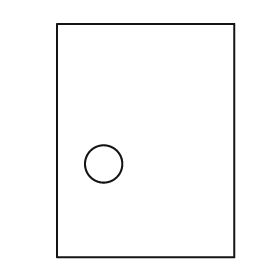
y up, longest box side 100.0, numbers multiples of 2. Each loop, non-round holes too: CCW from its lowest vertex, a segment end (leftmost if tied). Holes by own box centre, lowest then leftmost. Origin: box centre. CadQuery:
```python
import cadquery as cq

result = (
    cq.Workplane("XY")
    .moveTo(-38.0, -50.0)
    .lineTo(38.0, -50.0)
    .lineTo(38.0, 50.0)
    .lineTo(-38.0, 50.0)
    .close()
    .moveTo(-18.0, -10.0)
    .circle(8.0)
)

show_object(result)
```